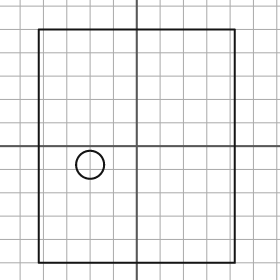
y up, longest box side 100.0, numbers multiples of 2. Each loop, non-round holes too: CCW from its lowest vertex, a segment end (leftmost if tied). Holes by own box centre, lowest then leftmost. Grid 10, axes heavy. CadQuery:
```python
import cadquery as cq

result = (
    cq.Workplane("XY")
    .moveTo(-42.0, -50.0)
    .lineTo(42.0, -50.0)
    .lineTo(42.0, 50.0)
    .lineTo(-42.0, 50.0)
    .close()
    .moveTo(-20.0, -8.0)
    .circle(6.0)
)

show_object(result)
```